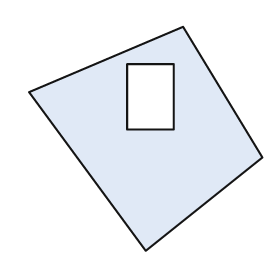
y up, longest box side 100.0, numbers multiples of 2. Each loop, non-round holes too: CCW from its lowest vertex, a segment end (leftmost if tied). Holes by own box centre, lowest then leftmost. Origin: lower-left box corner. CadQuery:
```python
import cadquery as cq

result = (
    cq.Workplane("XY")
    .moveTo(50.0, 0.0)
    .lineTo(100.0, 40.0)
    .lineTo(66.0, 96.0)
    .lineTo(0.0, 68.0)
    .close()
    .moveTo(42.0, 52.0)
    .lineTo(62.0, 52.0)
    .lineTo(62.0, 80.0)
    .lineTo(42.0, 80.0)
    .close()
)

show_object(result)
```